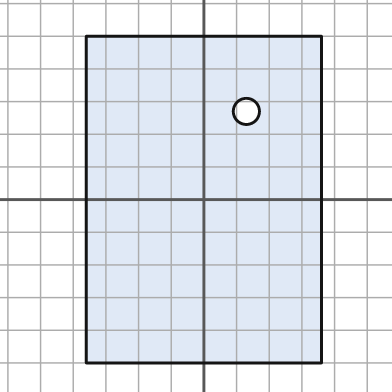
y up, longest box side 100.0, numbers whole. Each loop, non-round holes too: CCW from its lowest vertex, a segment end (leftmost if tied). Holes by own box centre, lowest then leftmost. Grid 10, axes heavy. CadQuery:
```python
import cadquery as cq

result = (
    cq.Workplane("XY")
    .moveTo(-36.0, -50.0)
    .lineTo(36.0, -50.0)
    .lineTo(36.0, 50.0)
    .lineTo(-36.0, 50.0)
    .close()
    .moveTo(13.0, 27.0)
    .circle(4.0)
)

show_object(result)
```